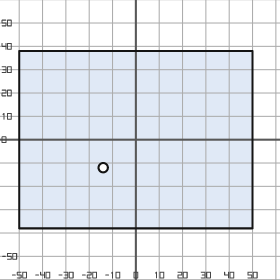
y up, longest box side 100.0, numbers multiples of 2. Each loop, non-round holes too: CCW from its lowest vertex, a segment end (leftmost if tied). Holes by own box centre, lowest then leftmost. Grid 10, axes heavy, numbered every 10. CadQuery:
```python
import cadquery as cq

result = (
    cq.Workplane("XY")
    .moveTo(-50.0, -38.0)
    .lineTo(50.0, -38.0)
    .lineTo(50.0, 38.0)
    .lineTo(-50.0, 38.0)
    .close()
    .moveTo(-14.0, -12.0)
    .circle(2.0)
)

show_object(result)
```